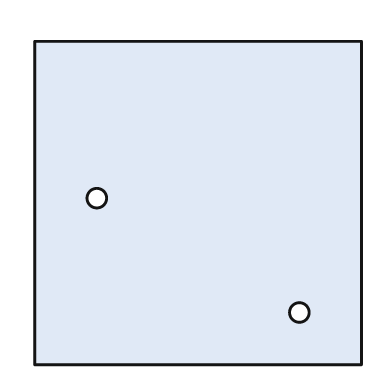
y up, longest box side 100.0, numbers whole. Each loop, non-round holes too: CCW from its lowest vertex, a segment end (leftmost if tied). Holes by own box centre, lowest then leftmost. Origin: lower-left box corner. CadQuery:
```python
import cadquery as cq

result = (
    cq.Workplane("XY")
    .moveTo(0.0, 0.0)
    .lineTo(100.0, 0.0)
    .lineTo(100.0, 99.0)
    .lineTo(0.0, 99.0)
    .close()
    .moveTo(81.0, 16.0)
    .circle(3.0)
    .moveTo(19.0, 51.0)
    .circle(3.0)
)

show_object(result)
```